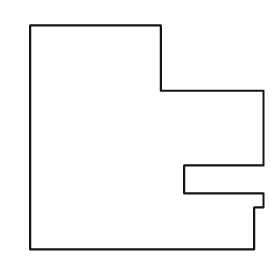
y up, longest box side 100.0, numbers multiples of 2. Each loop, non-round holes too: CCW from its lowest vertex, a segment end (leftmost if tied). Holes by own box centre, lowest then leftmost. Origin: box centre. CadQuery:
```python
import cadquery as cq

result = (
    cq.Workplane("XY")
    .moveTo(-50.0, -48.0)
    .lineTo(46.0, -48.0)
    .lineTo(46.0, -30.0)
    .lineTo(50.0, -30.0)
    .lineTo(50.0, -24.0)
    .lineTo(16.0, -24.0)
    .lineTo(16.0, -12.0)
    .lineTo(50.0, -12.0)
    .lineTo(50.0, 20.0)
    .lineTo(6.0, 20.0)
    .lineTo(6.0, 48.0)
    .lineTo(-50.0, 48.0)
    .close()
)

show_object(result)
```